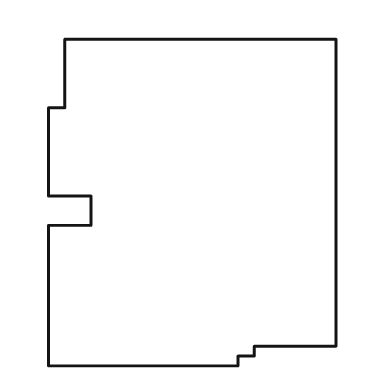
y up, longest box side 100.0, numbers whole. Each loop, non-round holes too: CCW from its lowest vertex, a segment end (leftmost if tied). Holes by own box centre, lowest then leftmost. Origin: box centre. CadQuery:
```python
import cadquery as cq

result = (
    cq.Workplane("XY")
    .moveTo(-44.0, -50.0)
    .lineTo(14.0, -50.0)
    .lineTo(14.0, -47.0)
    .lineTo(19.0, -47.0)
    .lineTo(19.0, -44.0)
    .lineTo(44.0, -44.0)
    .lineTo(44.0, 50.0)
    .lineTo(-39.0, 50.0)
    .lineTo(-39.0, 29.0)
    .lineTo(-44.0, 29.0)
    .lineTo(-44.0, 2.0)
    .lineTo(-31.0, 2.0)
    .lineTo(-31.0, -7.0)
    .lineTo(-44.0, -7.0)
    .close()
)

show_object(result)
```